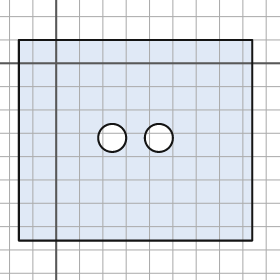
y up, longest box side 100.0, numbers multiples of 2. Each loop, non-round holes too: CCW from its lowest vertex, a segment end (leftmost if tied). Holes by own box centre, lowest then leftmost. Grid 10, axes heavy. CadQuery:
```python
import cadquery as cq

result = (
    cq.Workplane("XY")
    .moveTo(-16.0, -76.0)
    .lineTo(84.0, -76.0)
    .lineTo(84.0, 10.0)
    .lineTo(-16.0, 10.0)
    .close()
    .moveTo(24.0, -32.0)
    .circle(6.0)
    .moveTo(44.0, -32.0)
    .circle(6.0)
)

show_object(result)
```